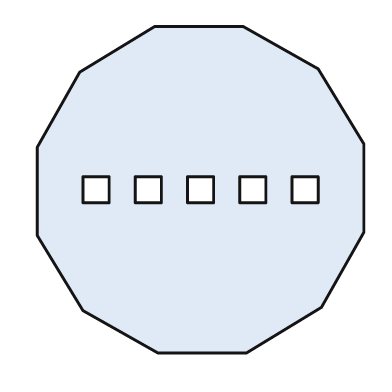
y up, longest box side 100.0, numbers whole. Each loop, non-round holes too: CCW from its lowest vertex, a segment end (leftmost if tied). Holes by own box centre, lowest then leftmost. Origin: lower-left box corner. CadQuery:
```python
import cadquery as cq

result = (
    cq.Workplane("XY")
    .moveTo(37.0, 0.0)
    .lineTo(64.0, 0.0)
    .lineTo(87.0, 14.0)
    .lineTo(100.0, 37.0)
    .lineTo(100.0, 64.0)
    .lineTo(86.0, 87.0)
    .lineTo(63.0, 100.0)
    .lineTo(36.0, 100.0)
    .lineTo(13.0, 86.0)
    .lineTo(0.0, 63.0)
    .lineTo(0.0, 36.0)
    .lineTo(14.0, 13.0)
    .close()
    .moveTo(14.0, 46.0)
    .lineTo(22.0, 46.0)
    .lineTo(22.0, 54.0)
    .lineTo(14.0, 54.0)
    .close()
    .moveTo(30.0, 46.0)
    .lineTo(38.0, 46.0)
    .lineTo(38.0, 54.0)
    .lineTo(30.0, 54.0)
    .close()
    .moveTo(46.0, 46.0)
    .lineTo(54.0, 46.0)
    .lineTo(54.0, 54.0)
    .lineTo(46.0, 54.0)
    .close()
    .moveTo(62.0, 46.0)
    .lineTo(70.0, 46.0)
    .lineTo(70.0, 54.0)
    .lineTo(62.0, 54.0)
    .close()
    .moveTo(78.0, 46.0)
    .lineTo(86.0, 46.0)
    .lineTo(86.0, 54.0)
    .lineTo(78.0, 54.0)
    .close()
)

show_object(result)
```